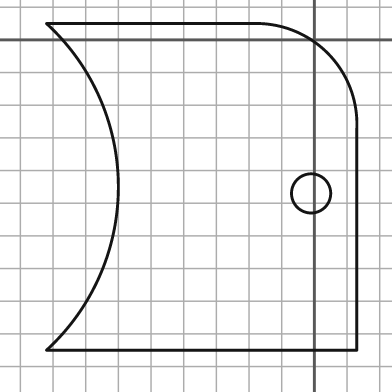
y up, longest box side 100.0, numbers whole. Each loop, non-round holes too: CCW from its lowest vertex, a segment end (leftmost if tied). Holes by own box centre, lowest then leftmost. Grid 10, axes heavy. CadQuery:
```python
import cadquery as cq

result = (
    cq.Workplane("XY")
    .moveTo(-82.0, -95.0)
    .lineTo(13.0, -95.0)
    .lineTo(13.0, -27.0)
    .threePointArc((4.0, -4.0), (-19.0, 5.0))
    .lineTo(-82.0, 5.0)
    .threePointArc((-60.0, -45.0), (-82.0, -95.0))
    .close()
    .moveTo(-1.0, -47.0)
    .circle(6.0)
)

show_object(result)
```